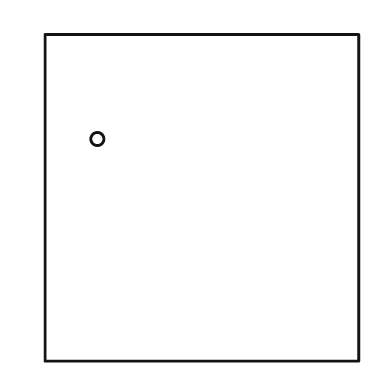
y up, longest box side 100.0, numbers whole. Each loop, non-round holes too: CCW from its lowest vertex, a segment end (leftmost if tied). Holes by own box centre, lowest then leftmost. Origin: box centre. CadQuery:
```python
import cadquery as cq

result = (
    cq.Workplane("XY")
    .moveTo(-48.0, -50.0)
    .lineTo(48.0, -50.0)
    .lineTo(48.0, 50.0)
    .lineTo(-48.0, 50.0)
    .close()
    .moveTo(-32.0, 18.0)
    .circle(2.0)
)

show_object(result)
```